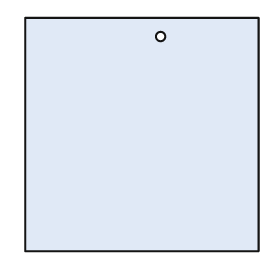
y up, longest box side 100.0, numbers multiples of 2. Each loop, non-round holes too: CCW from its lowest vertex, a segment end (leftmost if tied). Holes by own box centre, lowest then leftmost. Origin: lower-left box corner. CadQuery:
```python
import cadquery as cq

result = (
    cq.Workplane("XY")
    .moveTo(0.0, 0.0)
    .lineTo(100.0, 0.0)
    .lineTo(100.0, 100.0)
    .lineTo(0.0, 100.0)
    .close()
    .moveTo(58.0, 92.0)
    .circle(2.0)
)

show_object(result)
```